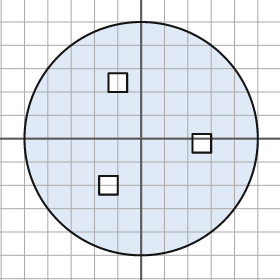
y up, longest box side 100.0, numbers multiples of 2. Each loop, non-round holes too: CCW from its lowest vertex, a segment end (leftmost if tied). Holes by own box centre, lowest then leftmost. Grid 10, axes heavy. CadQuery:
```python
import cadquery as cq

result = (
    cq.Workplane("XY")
    .moveTo(0.0, 0.0)
    .circle(50.0)
    .moveTo(-18.0, -24.0)
    .lineTo(-10.0, -24.0)
    .lineTo(-10.0, -16.0)
    .lineTo(-18.0, -16.0)
    .close()
    .moveTo(22.0, -6.0)
    .lineTo(30.0, -6.0)
    .lineTo(30.0, 2.0)
    .lineTo(22.0, 2.0)
    .close()
    .moveTo(-14.0, 20.0)
    .lineTo(-6.0, 20.0)
    .lineTo(-6.0, 28.0)
    .lineTo(-14.0, 28.0)
    .close()
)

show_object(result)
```